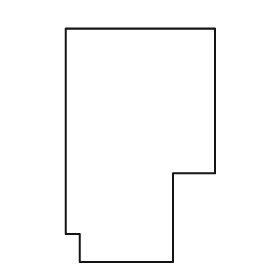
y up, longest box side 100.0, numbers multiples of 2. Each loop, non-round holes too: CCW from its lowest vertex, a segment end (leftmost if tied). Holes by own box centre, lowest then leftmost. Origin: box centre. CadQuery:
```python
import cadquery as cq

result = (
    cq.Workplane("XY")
    .moveTo(-26.0, -50.0)
    .lineTo(14.0, -50.0)
    .lineTo(14.0, -12.0)
    .lineTo(32.0, -12.0)
    .lineTo(32.0, 50.0)
    .lineTo(-32.0, 50.0)
    .lineTo(-32.0, -38.0)
    .lineTo(-26.0, -38.0)
    .close()
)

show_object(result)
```